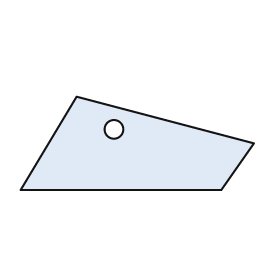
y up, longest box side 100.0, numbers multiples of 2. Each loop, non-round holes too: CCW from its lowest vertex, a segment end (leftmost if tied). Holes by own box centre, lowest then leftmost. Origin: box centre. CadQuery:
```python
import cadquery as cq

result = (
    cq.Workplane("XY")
    .moveTo(-50.0, -20.0)
    .lineTo(36.0, -20.0)
    .lineTo(50.0, 0.0)
    .lineTo(-26.0, 20.0)
    .close()
    .moveTo(-10.0, 6.0)
    .circle(4.0)
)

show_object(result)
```